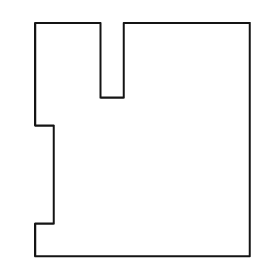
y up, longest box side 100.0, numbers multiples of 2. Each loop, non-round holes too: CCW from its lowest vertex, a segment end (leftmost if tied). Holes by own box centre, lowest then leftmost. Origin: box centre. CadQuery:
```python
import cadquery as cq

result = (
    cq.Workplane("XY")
    .moveTo(-46.0, -50.0)
    .lineTo(46.0, -50.0)
    .lineTo(46.0, 50.0)
    .lineTo(-8.0, 50.0)
    .lineTo(-8.0, 18.0)
    .lineTo(-18.0, 18.0)
    .lineTo(-18.0, 50.0)
    .lineTo(-46.0, 50.0)
    .lineTo(-46.0, 6.0)
    .lineTo(-38.0, 6.0)
    .lineTo(-38.0, -36.0)
    .lineTo(-46.0, -36.0)
    .close()
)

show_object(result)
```